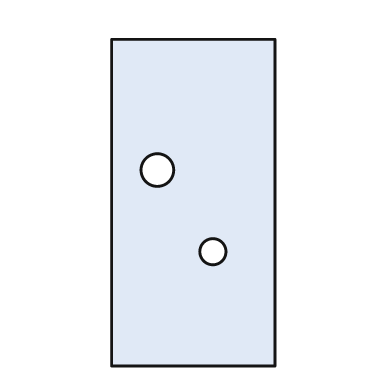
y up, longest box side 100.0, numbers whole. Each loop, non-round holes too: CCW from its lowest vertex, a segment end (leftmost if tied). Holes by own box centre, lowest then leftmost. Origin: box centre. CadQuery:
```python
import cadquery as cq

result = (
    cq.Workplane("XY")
    .moveTo(-25.0, -50.0)
    .lineTo(25.0, -50.0)
    .lineTo(25.0, 50.0)
    .lineTo(-25.0, 50.0)
    .close()
    .moveTo(6.0, -15.0)
    .circle(4.0)
    .moveTo(-11.0, 10.0)
    .circle(5.0)
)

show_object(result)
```